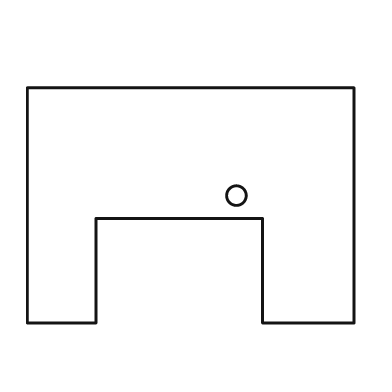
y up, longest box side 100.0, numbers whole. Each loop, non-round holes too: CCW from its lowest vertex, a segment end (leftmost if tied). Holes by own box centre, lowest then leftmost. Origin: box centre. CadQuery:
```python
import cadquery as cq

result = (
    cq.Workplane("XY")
    .moveTo(-50.0, -36.0)
    .lineTo(-29.0, -36.0)
    .lineTo(-29.0, -4.0)
    .lineTo(22.0, -4.0)
    .lineTo(22.0, -36.0)
    .lineTo(50.0, -36.0)
    .lineTo(50.0, 36.0)
    .lineTo(-50.0, 36.0)
    .close()
    .moveTo(14.0, 3.0)
    .circle(3.0)
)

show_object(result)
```